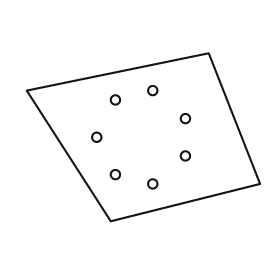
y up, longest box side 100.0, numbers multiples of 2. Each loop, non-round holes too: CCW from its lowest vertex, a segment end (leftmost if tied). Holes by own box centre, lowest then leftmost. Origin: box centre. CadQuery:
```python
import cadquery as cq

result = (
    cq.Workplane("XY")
    .moveTo(-14.0, -36.0)
    .lineTo(50.0, -20.0)
    .lineTo(28.0, 36.0)
    .lineTo(-50.0, 20.0)
    .close()
    .moveTo(4.0, -20.0)
    .circle(2.0)
    .moveTo(-12.0, -16.0)
    .circle(2.0)
    .moveTo(18.0, -8.0)
    .circle(2.0)
    .moveTo(-20.0, 0.0)
    .circle(2.0)
    .moveTo(18.0, 8.0)
    .circle(2.0)
    .moveTo(-12.0, 16.0)
    .circle(2.0)
    .moveTo(4.0, 20.0)
    .circle(2.0)
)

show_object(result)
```